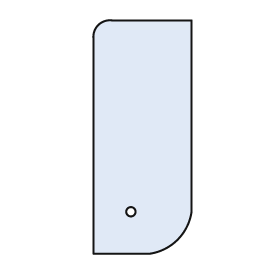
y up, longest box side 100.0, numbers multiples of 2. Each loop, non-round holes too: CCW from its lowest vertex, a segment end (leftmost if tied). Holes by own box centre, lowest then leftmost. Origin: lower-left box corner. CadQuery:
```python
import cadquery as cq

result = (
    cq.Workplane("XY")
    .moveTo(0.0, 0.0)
    .lineTo(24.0, 0.0)
    .threePointArc((36.0, 6.0), (42.0, 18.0))
    .lineTo(42.0, 100.0)
    .lineTo(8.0, 100.0)
    .threePointArc((2.0, 98.0), (0.0, 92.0))
    .close()
    .moveTo(16.0, 18.0)
    .circle(2.0)
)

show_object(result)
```